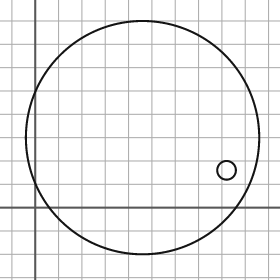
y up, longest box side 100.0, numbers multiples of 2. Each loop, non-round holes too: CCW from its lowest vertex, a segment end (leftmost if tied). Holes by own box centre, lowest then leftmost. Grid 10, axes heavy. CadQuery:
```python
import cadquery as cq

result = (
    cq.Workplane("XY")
    .moveTo(46.0, 30.0)
    .circle(50.0)
    .moveTo(82.0, 16.0)
    .circle(4.0)
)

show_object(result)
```